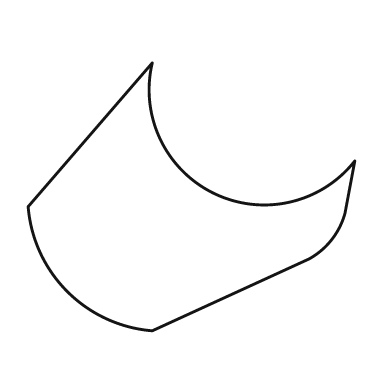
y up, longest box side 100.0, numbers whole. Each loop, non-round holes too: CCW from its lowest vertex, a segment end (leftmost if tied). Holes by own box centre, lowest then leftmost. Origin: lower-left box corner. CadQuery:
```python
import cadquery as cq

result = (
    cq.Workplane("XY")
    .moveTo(38.0, 0.0)
    .lineTo(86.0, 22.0)
    .threePointArc((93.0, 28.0), (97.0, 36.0))
    .lineTo(100.0, 52.0)
    .threePointArc((57.0, 42.0), (38.0, 82.0))
    .lineTo(0.0, 38.0)
    .threePointArc((12.0, 12.0), (38.0, 0.0))
    .close()
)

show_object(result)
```